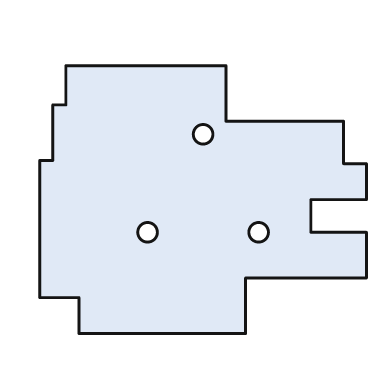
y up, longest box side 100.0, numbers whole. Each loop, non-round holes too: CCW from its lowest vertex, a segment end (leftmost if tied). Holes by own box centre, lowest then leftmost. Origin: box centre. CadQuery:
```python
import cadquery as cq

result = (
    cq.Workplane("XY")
    .moveTo(-38.0, -41.0)
    .lineTo(13.0, -41.0)
    .lineTo(13.0, -24.0)
    .lineTo(50.0, -24.0)
    .lineTo(50.0, -10.0)
    .lineTo(33.0, -10.0)
    .lineTo(33.0, 0.0)
    .lineTo(50.0, 0.0)
    .lineTo(50.0, 11.0)
    .lineTo(43.0, 11.0)
    .lineTo(43.0, 24.0)
    .lineTo(7.0, 24.0)
    .lineTo(7.0, 41.0)
    .lineTo(-42.0, 41.0)
    .lineTo(-42.0, 29.0)
    .lineTo(-46.0, 29.0)
    .lineTo(-46.0, 12.0)
    .lineTo(-50.0, 12.0)
    .lineTo(-50.0, -30.0)
    .lineTo(-38.0, -30.0)
    .close()
    .moveTo(-17.0, -10.0)
    .circle(3.0)
    .moveTo(17.0, -10.0)
    .circle(3.0)
    .moveTo(0.0, 20.0)
    .circle(3.0)
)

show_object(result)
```